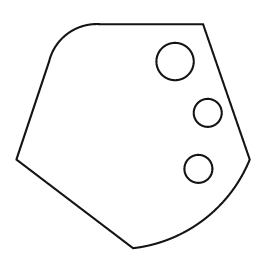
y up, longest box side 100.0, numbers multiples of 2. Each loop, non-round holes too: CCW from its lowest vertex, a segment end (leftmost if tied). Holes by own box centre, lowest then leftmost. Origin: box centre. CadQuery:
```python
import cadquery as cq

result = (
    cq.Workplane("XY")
    .moveTo(0.0, -48.0)
    .threePointArc((30.0, -36.0), (50.0, -10.0))
    .lineTo(30.0, 48.0)
    .lineTo(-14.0, 48.0)
    .threePointArc((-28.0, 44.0), (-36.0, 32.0))
    .lineTo(-50.0, -10.0)
    .close()
    .moveTo(28.0, -14.0)
    .circle(6.0)
    .moveTo(32.0, 10.0)
    .circle(6.0)
    .moveTo(18.0, 32.0)
    .circle(8.0)
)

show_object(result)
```